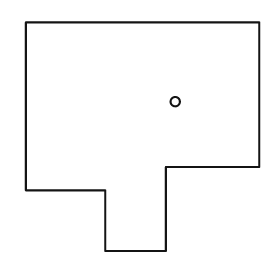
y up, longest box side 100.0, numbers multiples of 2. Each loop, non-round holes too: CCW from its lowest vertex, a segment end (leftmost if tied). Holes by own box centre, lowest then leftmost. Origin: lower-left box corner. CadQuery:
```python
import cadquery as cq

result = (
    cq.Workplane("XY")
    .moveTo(34.0, 0.0)
    .lineTo(60.0, 0.0)
    .lineTo(60.0, 36.0)
    .lineTo(100.0, 36.0)
    .lineTo(100.0, 98.0)
    .lineTo(0.0, 98.0)
    .lineTo(0.0, 26.0)
    .lineTo(34.0, 26.0)
    .close()
    .moveTo(64.0, 64.0)
    .circle(2.0)
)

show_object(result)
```